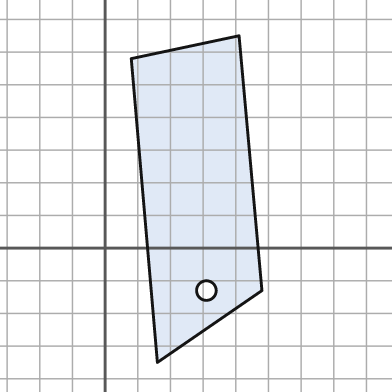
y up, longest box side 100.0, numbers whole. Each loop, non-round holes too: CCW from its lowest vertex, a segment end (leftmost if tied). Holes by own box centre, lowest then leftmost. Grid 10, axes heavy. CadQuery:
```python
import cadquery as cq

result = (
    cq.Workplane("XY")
    .moveTo(16.0, -35.0)
    .lineTo(48.0, -13.0)
    .lineTo(41.0, 65.0)
    .lineTo(8.0, 58.0)
    .close()
    .moveTo(31.0, -13.0)
    .circle(3.0)
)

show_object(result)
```